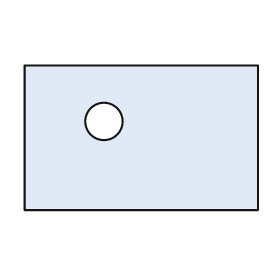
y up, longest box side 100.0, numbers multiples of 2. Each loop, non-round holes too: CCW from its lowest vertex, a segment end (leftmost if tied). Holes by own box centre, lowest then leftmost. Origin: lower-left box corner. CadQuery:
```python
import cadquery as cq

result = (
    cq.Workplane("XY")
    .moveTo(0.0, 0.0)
    .lineTo(100.0, 0.0)
    .lineTo(100.0, 62.0)
    .lineTo(0.0, 62.0)
    .close()
    .moveTo(34.0, 38.0)
    .circle(8.0)
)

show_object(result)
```